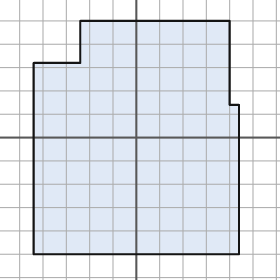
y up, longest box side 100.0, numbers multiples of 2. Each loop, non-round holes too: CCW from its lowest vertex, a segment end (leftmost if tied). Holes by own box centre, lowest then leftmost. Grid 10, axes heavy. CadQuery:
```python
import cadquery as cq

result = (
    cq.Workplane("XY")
    .moveTo(-44.0, -50.0)
    .lineTo(44.0, -50.0)
    .lineTo(44.0, 14.0)
    .lineTo(40.0, 14.0)
    .lineTo(40.0, 50.0)
    .lineTo(-24.0, 50.0)
    .lineTo(-24.0, 32.0)
    .lineTo(-44.0, 32.0)
    .close()
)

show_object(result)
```